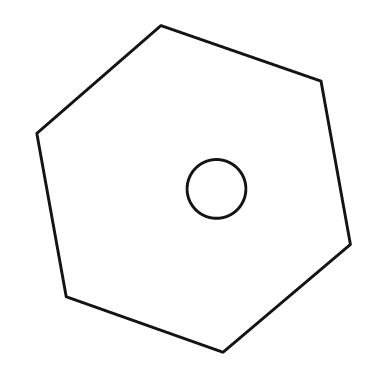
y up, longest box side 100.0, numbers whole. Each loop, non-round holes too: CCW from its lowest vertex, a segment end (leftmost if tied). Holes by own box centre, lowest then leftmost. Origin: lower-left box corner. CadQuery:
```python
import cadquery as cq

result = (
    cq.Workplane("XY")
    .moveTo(57.0, 0.0)
    .lineTo(96.0, 33.0)
    .lineTo(87.0, 83.0)
    .lineTo(38.0, 100.0)
    .lineTo(0.0, 67.0)
    .lineTo(9.0, 17.0)
    .close()
    .moveTo(55.0, 50.0)
    .circle(9.0)
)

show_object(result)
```